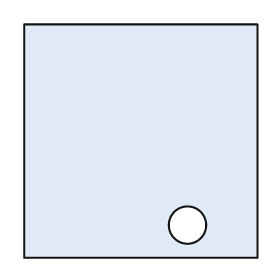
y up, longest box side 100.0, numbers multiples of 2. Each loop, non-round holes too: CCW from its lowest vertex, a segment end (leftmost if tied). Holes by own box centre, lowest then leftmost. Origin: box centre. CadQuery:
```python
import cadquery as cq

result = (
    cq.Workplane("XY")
    .moveTo(-50.0, -50.0)
    .lineTo(50.0, -50.0)
    .lineTo(50.0, 50.0)
    .lineTo(-50.0, 50.0)
    .close()
    .moveTo(20.0, -36.0)
    .circle(8.0)
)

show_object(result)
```